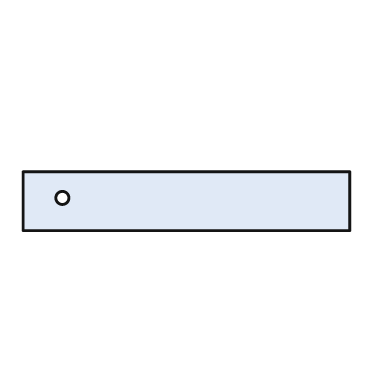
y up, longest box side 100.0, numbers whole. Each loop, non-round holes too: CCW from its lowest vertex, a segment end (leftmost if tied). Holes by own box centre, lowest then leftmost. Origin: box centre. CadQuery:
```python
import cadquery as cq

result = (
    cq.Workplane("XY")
    .moveTo(-50.0, -9.0)
    .lineTo(50.0, -9.0)
    .lineTo(50.0, 9.0)
    .lineTo(-50.0, 9.0)
    .close()
    .moveTo(-38.0, 1.0)
    .circle(2.0)
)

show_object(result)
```